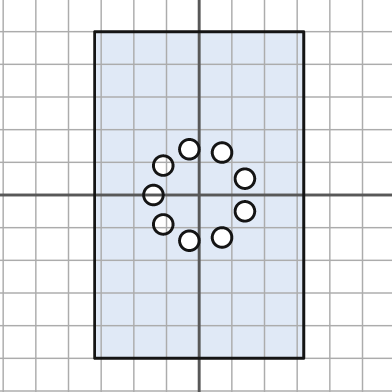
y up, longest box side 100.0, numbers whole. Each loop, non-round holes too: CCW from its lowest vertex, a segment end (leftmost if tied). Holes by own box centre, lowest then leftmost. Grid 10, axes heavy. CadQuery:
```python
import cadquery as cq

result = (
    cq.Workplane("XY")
    .moveTo(-32.0, -50.0)
    .lineTo(32.0, -50.0)
    .lineTo(32.0, 50.0)
    .lineTo(-32.0, 50.0)
    .close()
    .moveTo(-3.0, -14.0)
    .circle(3.0)
    .moveTo(7.0, -13.0)
    .circle(3.0)
    .moveTo(-11.0, -9.0)
    .circle(3.0)
    .moveTo(14.0, -5.0)
    .circle(3.0)
    .moveTo(-14.0, 0.0)
    .circle(3.0)
    .moveTo(14.0, 5.0)
    .circle(3.0)
    .moveTo(-11.0, 9.0)
    .circle(3.0)
    .moveTo(7.0, 13.0)
    .circle(3.0)
    .moveTo(-3.0, 14.0)
    .circle(3.0)
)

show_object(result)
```